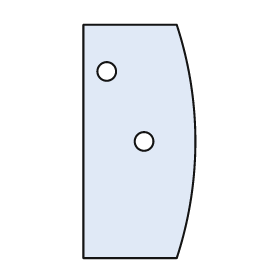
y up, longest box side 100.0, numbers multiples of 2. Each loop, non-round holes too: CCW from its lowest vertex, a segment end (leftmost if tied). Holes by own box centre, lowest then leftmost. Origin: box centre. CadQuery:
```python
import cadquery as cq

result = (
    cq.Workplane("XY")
    .moveTo(-24.0, -50.0)
    .lineTo(16.0, -50.0)
    .threePointArc((24.0, 0.0), (16.0, 50.0))
    .lineTo(-24.0, 50.0)
    .close()
    .moveTo(2.0, 0.0)
    .circle(4.0)
    .moveTo(-14.0, 30.0)
    .circle(4.0)
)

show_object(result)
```